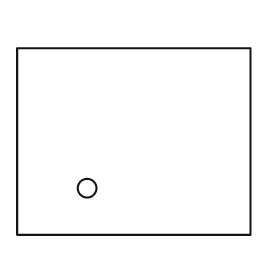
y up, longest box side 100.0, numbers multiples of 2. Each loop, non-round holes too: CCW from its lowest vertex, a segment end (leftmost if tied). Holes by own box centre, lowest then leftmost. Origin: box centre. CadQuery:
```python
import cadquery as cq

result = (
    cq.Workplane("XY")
    .moveTo(-50.0, -40.0)
    .lineTo(50.0, -40.0)
    .lineTo(50.0, 40.0)
    .lineTo(-50.0, 40.0)
    .close()
    .moveTo(-20.0, -20.0)
    .circle(4.0)
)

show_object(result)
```